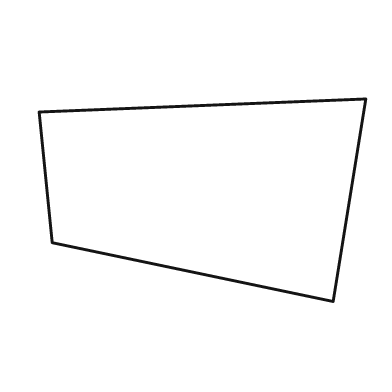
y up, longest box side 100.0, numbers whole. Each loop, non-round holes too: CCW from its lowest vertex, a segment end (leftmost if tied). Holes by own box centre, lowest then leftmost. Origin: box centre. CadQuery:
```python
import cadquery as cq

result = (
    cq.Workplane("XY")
    .moveTo(40.0, -31.0)
    .lineTo(50.0, 31.0)
    .lineTo(-50.0, 27.0)
    .lineTo(-46.0, -13.0)
    .close()
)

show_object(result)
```